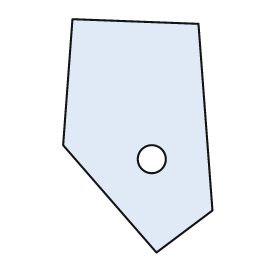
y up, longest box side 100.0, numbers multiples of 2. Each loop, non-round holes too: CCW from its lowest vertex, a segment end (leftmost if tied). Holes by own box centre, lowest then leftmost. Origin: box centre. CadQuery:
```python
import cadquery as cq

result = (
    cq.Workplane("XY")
    .moveTo(8.0, -50.0)
    .lineTo(32.0, -32.0)
    .lineTo(26.0, 48.0)
    .lineTo(-28.0, 50.0)
    .lineTo(-32.0, -4.0)
    .close()
    .moveTo(6.0, -10.0)
    .circle(6.0)
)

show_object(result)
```